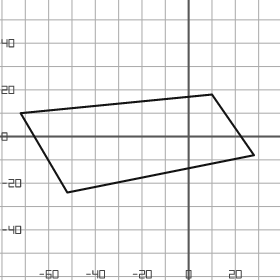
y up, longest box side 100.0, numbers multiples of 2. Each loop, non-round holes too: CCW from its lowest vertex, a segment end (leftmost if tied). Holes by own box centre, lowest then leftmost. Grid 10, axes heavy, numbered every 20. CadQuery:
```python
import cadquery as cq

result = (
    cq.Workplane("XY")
    .moveTo(-52.0, -24.0)
    .lineTo(28.0, -8.0)
    .lineTo(10.0, 18.0)
    .lineTo(-72.0, 10.0)
    .close()
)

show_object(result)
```